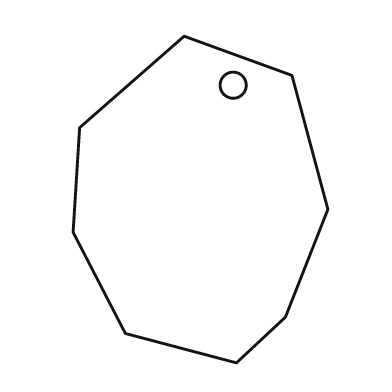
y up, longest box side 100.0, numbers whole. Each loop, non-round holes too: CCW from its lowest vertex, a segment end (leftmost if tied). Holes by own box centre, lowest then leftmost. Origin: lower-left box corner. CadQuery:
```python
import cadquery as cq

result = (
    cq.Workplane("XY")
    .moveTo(50.0, 0.0)
    .lineTo(65.0, 14.0)
    .lineTo(78.0, 47.0)
    .lineTo(67.0, 88.0)
    .lineTo(34.0, 100.0)
    .lineTo(2.0, 72.0)
    .lineTo(0.0, 40.0)
    .lineTo(16.0, 9.0)
    .close()
    .moveTo(49.0, 85.0)
    .circle(4.0)
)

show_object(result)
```